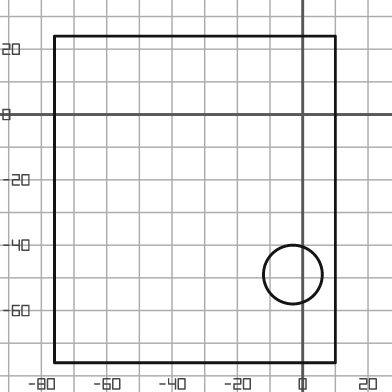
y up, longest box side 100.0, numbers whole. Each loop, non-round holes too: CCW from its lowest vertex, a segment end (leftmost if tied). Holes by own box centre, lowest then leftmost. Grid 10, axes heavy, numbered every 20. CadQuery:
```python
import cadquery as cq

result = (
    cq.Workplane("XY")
    .moveTo(-76.0, -76.0)
    .lineTo(10.0, -76.0)
    .lineTo(10.0, 24.0)
    .lineTo(-76.0, 24.0)
    .close()
    .moveTo(-3.0, -49.0)
    .circle(9.0)
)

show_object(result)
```